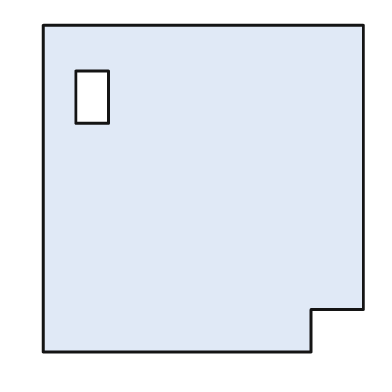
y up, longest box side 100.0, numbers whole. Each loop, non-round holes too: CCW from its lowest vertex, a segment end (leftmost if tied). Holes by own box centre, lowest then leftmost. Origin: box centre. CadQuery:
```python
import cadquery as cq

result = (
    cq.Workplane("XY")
    .moveTo(-49.0, -50.0)
    .lineTo(33.0, -50.0)
    .lineTo(33.0, -37.0)
    .lineTo(49.0, -37.0)
    .lineTo(49.0, 50.0)
    .lineTo(-49.0, 50.0)
    .close()
    .moveTo(-39.0, 20.0)
    .lineTo(-29.0, 20.0)
    .lineTo(-29.0, 36.0)
    .lineTo(-39.0, 36.0)
    .close()
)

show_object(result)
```